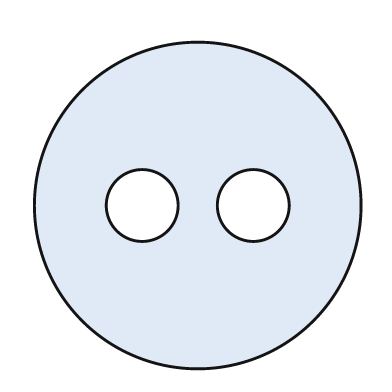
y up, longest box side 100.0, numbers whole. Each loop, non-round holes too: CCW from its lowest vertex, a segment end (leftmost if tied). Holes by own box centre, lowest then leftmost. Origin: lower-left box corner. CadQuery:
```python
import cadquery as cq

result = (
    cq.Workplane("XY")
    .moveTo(50.0, 50.0)
    .circle(50.0)
    .moveTo(33.0, 50.0)
    .circle(11.0)
    .moveTo(67.0, 50.0)
    .circle(11.0)
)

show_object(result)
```